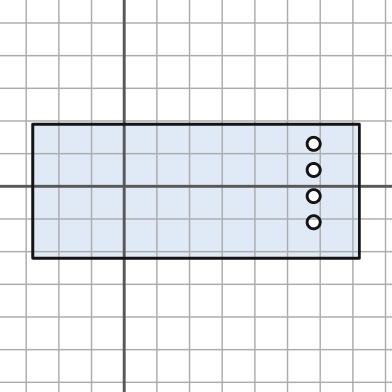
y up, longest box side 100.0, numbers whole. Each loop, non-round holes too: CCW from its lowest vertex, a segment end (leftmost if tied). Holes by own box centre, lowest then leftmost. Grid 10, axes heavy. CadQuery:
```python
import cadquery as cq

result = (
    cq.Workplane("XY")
    .moveTo(-28.0, -22.0)
    .lineTo(72.0, -22.0)
    .lineTo(72.0, 19.0)
    .lineTo(-28.0, 19.0)
    .close()
    .moveTo(58.0, -11.0)
    .circle(2.0)
    .moveTo(58.0, -3.0)
    .circle(2.0)
    .moveTo(58.0, 5.0)
    .circle(2.0)
    .moveTo(58.0, 13.0)
    .circle(2.0)
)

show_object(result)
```